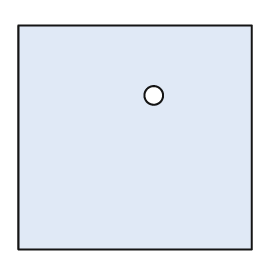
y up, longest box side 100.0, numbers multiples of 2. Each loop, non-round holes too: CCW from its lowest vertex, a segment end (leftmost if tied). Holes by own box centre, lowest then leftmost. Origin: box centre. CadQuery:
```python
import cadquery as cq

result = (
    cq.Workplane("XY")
    .moveTo(-50.0, -48.0)
    .lineTo(50.0, -48.0)
    .lineTo(50.0, 48.0)
    .lineTo(-50.0, 48.0)
    .close()
    .moveTo(8.0, 18.0)
    .circle(4.0)
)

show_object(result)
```